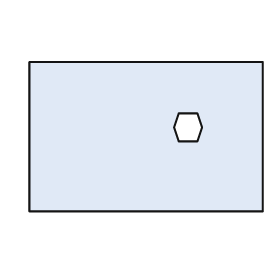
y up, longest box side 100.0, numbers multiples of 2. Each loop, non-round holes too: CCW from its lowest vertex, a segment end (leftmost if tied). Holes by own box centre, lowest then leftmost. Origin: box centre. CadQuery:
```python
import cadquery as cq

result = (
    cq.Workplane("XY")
    .moveTo(-50.0, -32.0)
    .lineTo(50.0, -32.0)
    .lineTo(50.0, 32.0)
    .lineTo(-50.0, 32.0)
    .close()
    .moveTo(14.0, -2.0)
    .lineTo(22.0, -2.0)
    .lineTo(24.0, 4.0)
    .lineTo(22.0, 10.0)
    .lineTo(14.0, 10.0)
    .lineTo(12.0, 4.0)
    .close()
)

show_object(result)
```